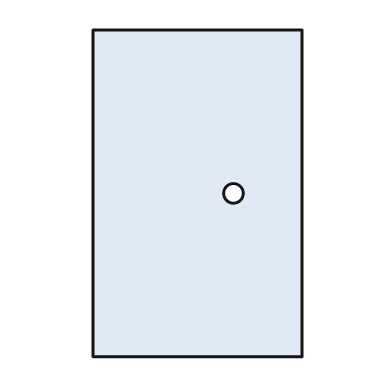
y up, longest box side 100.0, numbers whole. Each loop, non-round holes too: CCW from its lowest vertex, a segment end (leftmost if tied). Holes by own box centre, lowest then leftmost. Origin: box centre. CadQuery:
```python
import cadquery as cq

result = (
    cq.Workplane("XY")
    .moveTo(-32.0, -50.0)
    .lineTo(32.0, -50.0)
    .lineTo(32.0, 50.0)
    .lineTo(-32.0, 50.0)
    .close()
    .moveTo(11.0, 0.0)
    .circle(3.0)
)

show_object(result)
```